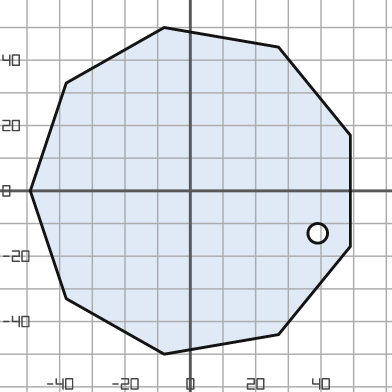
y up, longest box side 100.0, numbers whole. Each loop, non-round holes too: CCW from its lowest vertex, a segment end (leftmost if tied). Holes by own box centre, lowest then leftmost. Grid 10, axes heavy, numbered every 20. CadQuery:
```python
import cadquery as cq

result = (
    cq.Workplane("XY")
    .moveTo(-8.0, -50.0)
    .lineTo(27.0, -44.0)
    .lineTo(49.0, -17.0)
    .lineTo(49.0, 17.0)
    .lineTo(27.0, 44.0)
    .lineTo(-8.0, 50.0)
    .lineTo(-38.0, 33.0)
    .lineTo(-49.0, 0.0)
    .lineTo(-38.0, -33.0)
    .close()
    .moveTo(39.0, -13.0)
    .circle(3.0)
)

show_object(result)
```